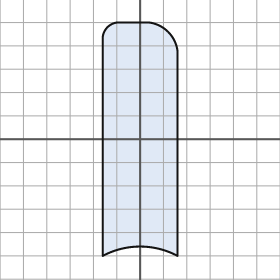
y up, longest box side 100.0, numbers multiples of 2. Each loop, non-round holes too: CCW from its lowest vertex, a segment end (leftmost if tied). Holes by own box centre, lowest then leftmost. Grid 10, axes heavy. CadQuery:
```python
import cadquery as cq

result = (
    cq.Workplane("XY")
    .moveTo(-16.0, -50.0)
    .threePointArc((0.0, -46.0), (16.0, -50.0))
    .lineTo(16.0, 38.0)
    .threePointArc((12.0, 46.0), (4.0, 50.0))
    .lineTo(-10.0, 50.0)
    .threePointArc((-14.0, 48.0), (-16.0, 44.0))
    .close()
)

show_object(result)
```